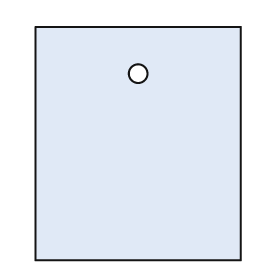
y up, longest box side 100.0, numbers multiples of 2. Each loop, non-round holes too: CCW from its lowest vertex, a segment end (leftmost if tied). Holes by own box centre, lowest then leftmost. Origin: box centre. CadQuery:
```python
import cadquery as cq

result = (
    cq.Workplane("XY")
    .moveTo(-44.0, -50.0)
    .lineTo(44.0, -50.0)
    .lineTo(44.0, 50.0)
    .lineTo(-44.0, 50.0)
    .close()
    .moveTo(0.0, 30.0)
    .circle(4.0)
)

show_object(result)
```